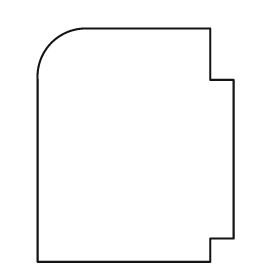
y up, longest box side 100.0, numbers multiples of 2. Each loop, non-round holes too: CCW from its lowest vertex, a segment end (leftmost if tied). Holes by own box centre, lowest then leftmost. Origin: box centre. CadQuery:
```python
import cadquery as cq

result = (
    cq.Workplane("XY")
    .moveTo(-42.0, -50.0)
    .lineTo(32.0, -50.0)
    .lineTo(32.0, -40.0)
    .lineTo(42.0, -40.0)
    .lineTo(42.0, 28.0)
    .lineTo(32.0, 28.0)
    .lineTo(32.0, 50.0)
    .lineTo(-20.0, 50.0)
    .threePointArc((-36.0, 44.0), (-42.0, 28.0))
    .close()
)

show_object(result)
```